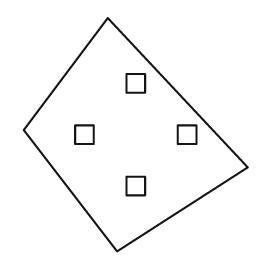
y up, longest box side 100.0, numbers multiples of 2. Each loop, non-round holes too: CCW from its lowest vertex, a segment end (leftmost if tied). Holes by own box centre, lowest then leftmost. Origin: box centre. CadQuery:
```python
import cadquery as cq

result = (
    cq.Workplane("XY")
    .moveTo(-8.0, -50.0)
    .lineTo(48.0, -14.0)
    .lineTo(-12.0, 50.0)
    .lineTo(-48.0, 2.0)
    .close()
    .moveTo(-4.0, -26.0)
    .lineTo(4.0, -26.0)
    .lineTo(4.0, -18.0)
    .lineTo(-4.0, -18.0)
    .close()
    .moveTo(-26.0, -4.0)
    .lineTo(-18.0, -4.0)
    .lineTo(-18.0, 4.0)
    .lineTo(-26.0, 4.0)
    .close()
    .moveTo(18.0, -4.0)
    .lineTo(26.0, -4.0)
    .lineTo(26.0, 4.0)
    .lineTo(18.0, 4.0)
    .close()
    .moveTo(-4.0, 18.0)
    .lineTo(4.0, 18.0)
    .lineTo(4.0, 26.0)
    .lineTo(-4.0, 26.0)
    .close()
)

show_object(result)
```